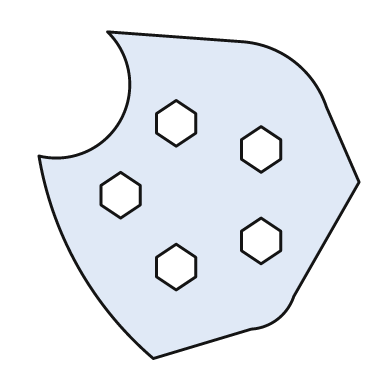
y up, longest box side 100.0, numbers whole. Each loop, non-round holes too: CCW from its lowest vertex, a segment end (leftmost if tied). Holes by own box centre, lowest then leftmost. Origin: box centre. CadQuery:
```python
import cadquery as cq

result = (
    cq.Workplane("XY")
    .moveTo(-14.0, -50.0)
    .lineTo(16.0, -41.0)
    .threePointArc((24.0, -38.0), (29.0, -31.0))
    .lineTo(49.0, 4.0)
    .lineTo(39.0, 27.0)
    .threePointArc((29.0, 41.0), (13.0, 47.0))
    .lineTo(-28.0, 50.0)
    .threePointArc((-24.0, 23.0), (-49.0, 12.0))
    .threePointArc((-37.0, -22.0), (-14.0, -50.0))
    .close()
    .moveTo(-7.0, -29.0)
    .lineTo(-1.0, -25.0)
    .lineTo(-1.0, -19.0)
    .lineTo(-7.0, -15.0)
    .lineTo(-13.0, -19.0)
    .lineTo(-13.0, -25.0)
    .close()
    .moveTo(19.0, -21.0)
    .lineTo(25.0, -17.0)
    .lineTo(25.0, -11.0)
    .lineTo(19.0, -7.0)
    .lineTo(13.0, -11.0)
    .lineTo(13.0, -17.0)
    .close()
    .moveTo(-24.0, -7.0)
    .lineTo(-18.0, -3.0)
    .lineTo(-18.0, 3.0)
    .lineTo(-24.0, 7.0)
    .lineTo(-30.0, 3.0)
    .lineTo(-30.0, -3.0)
    .close()
    .moveTo(19.0, 7.0)
    .lineTo(25.0, 11.0)
    .lineTo(25.0, 17.0)
    .lineTo(19.0, 21.0)
    .lineTo(13.0, 17.0)
    .lineTo(13.0, 11.0)
    .close()
    .moveTo(-7.0, 15.0)
    .lineTo(-1.0, 19.0)
    .lineTo(-1.0, 25.0)
    .lineTo(-7.0, 29.0)
    .lineTo(-13.0, 25.0)
    .lineTo(-13.0, 19.0)
    .close()
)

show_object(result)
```